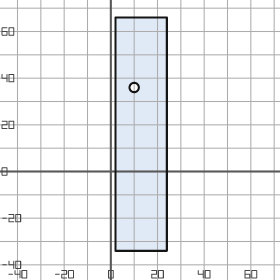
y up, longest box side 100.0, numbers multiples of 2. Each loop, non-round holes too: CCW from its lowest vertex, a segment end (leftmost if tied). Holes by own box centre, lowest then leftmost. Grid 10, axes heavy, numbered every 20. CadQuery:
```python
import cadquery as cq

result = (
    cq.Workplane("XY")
    .moveTo(2.0, -34.0)
    .lineTo(24.0, -34.0)
    .lineTo(24.0, 66.0)
    .lineTo(2.0, 66.0)
    .close()
    .moveTo(10.0, 36.0)
    .circle(2.0)
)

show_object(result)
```